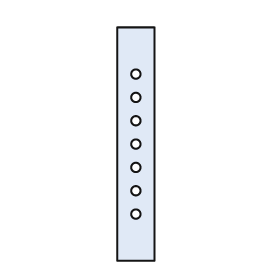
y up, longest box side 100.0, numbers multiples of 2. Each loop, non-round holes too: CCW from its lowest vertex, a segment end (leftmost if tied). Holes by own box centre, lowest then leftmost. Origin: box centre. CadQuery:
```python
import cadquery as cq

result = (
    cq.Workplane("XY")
    .moveTo(-8.0, -50.0)
    .lineTo(8.0, -50.0)
    .lineTo(8.0, 50.0)
    .lineTo(-8.0, 50.0)
    .close()
    .moveTo(0.0, -30.0)
    .circle(2.0)
    .moveTo(0.0, -20.0)
    .circle(2.0)
    .moveTo(0.0, -10.0)
    .circle(2.0)
    .moveTo(0.0, 0.0)
    .circle(2.0)
    .moveTo(0.0, 10.0)
    .circle(2.0)
    .moveTo(0.0, 20.0)
    .circle(2.0)
    .moveTo(0.0, 30.0)
    .circle(2.0)
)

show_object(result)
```